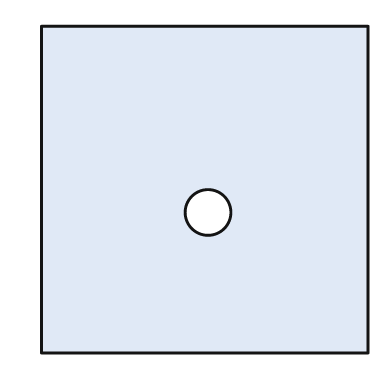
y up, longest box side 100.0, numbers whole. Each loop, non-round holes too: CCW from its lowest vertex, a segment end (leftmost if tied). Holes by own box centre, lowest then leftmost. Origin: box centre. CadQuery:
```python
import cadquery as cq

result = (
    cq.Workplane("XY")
    .moveTo(-50.0, -50.0)
    .lineTo(50.0, -50.0)
    .lineTo(50.0, 50.0)
    .lineTo(-50.0, 50.0)
    .close()
    .moveTo(1.0, -7.0)
    .circle(7.0)
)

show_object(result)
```